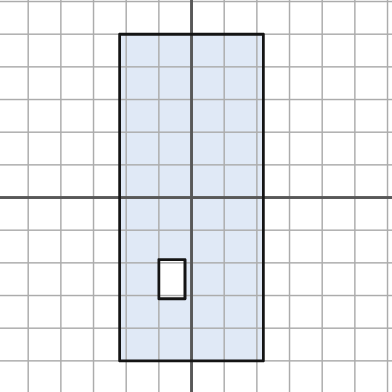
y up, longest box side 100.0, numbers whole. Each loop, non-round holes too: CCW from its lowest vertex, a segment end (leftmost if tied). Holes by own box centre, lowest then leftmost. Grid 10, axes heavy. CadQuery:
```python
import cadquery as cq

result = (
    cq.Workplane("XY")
    .moveTo(-22.0, -50.0)
    .lineTo(22.0, -50.0)
    .lineTo(22.0, 50.0)
    .lineTo(-22.0, 50.0)
    .close()
    .moveTo(-10.0, -31.0)
    .lineTo(-2.0, -31.0)
    .lineTo(-2.0, -19.0)
    .lineTo(-10.0, -19.0)
    .close()
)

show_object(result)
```